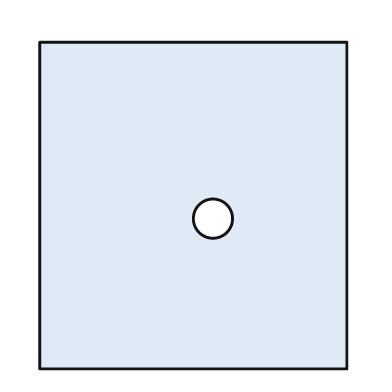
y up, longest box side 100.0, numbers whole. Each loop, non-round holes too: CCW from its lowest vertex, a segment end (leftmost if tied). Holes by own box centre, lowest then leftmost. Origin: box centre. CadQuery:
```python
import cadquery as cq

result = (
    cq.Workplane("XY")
    .moveTo(-47.0, -50.0)
    .lineTo(47.0, -50.0)
    .lineTo(47.0, 50.0)
    .lineTo(-47.0, 50.0)
    .close()
    .moveTo(6.0, -4.0)
    .circle(6.0)
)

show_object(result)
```